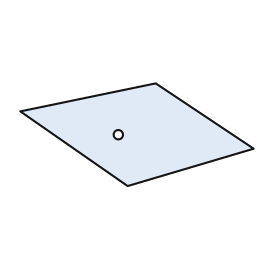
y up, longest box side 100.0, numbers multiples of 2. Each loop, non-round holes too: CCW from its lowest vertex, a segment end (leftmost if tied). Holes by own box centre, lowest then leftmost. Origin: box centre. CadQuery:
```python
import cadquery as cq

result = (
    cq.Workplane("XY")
    .moveTo(-4.0, -22.0)
    .lineTo(50.0, -6.0)
    .lineTo(8.0, 22.0)
    .lineTo(-50.0, 10.0)
    .close()
    .moveTo(-8.0, 0.0)
    .circle(2.0)
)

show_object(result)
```